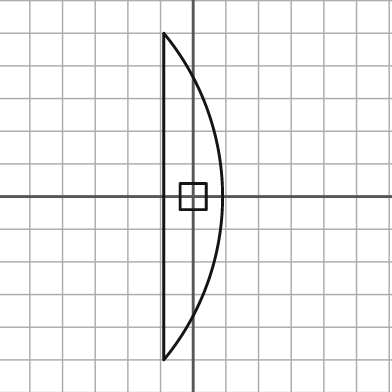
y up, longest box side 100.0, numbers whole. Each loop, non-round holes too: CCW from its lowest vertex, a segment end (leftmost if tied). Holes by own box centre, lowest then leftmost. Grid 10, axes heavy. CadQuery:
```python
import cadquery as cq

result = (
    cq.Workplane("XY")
    .moveTo(-9.0, -50.0)
    .threePointArc((9.0, 0.0), (-9.0, 50.0))
    .close()
    .moveTo(-4.0, -4.0)
    .lineTo(4.0, -4.0)
    .lineTo(4.0, 4.0)
    .lineTo(-4.0, 4.0)
    .close()
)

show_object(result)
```